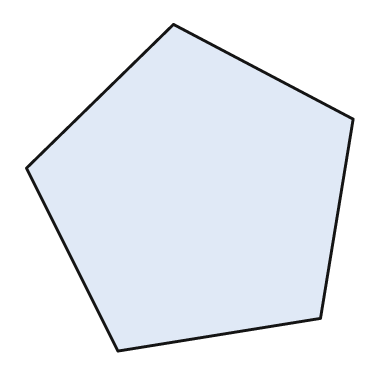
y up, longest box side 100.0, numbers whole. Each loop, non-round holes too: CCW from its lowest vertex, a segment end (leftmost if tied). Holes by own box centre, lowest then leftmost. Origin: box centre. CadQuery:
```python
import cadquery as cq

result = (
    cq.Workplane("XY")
    .moveTo(-22.0, -50.0)
    .lineTo(40.0, -40.0)
    .lineTo(50.0, 21.0)
    .lineTo(-5.0, 50.0)
    .lineTo(-50.0, 6.0)
    .close()
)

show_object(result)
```